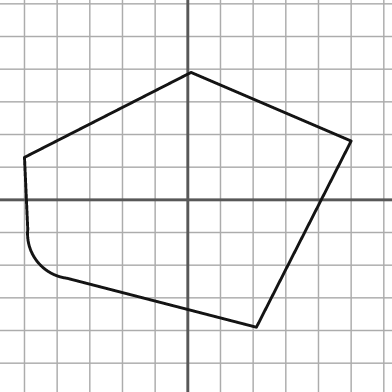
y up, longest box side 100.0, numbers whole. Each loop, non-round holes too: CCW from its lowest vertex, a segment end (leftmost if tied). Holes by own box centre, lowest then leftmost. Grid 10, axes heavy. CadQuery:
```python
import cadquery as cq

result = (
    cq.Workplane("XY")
    .moveTo(21.0, -39.0)
    .lineTo(50.0, 18.0)
    .lineTo(1.0, 39.0)
    .lineTo(-50.0, 13.0)
    .lineTo(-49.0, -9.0)
    .threePointArc((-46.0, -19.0), (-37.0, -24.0))
    .close()
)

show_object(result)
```